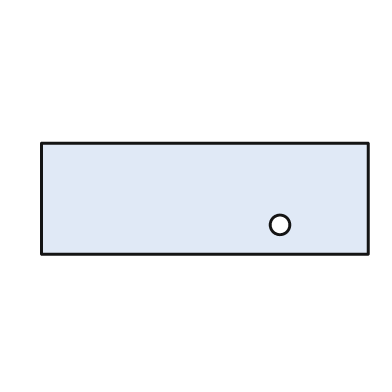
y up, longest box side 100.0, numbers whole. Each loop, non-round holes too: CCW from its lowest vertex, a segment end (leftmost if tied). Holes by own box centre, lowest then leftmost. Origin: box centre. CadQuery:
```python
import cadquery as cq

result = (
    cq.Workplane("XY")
    .moveTo(-50.0, -17.0)
    .lineTo(50.0, -17.0)
    .lineTo(50.0, 17.0)
    .lineTo(-50.0, 17.0)
    .close()
    .moveTo(23.0, -8.0)
    .circle(3.0)
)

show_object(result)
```